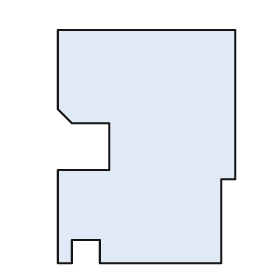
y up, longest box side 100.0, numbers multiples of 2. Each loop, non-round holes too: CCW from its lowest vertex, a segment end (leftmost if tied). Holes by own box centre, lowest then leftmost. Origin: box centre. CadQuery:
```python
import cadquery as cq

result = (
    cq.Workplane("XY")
    .moveTo(-38.0, -50.0)
    .lineTo(-32.0, -50.0)
    .lineTo(-32.0, -40.0)
    .lineTo(-20.0, -40.0)
    .lineTo(-20.0, -50.0)
    .lineTo(32.0, -50.0)
    .lineTo(32.0, -14.0)
    .lineTo(38.0, -14.0)
    .lineTo(38.0, 50.0)
    .lineTo(-38.0, 50.0)
    .lineTo(-38.0, 16.0)
    .lineTo(-32.0, 10.0)
    .lineTo(-16.0, 10.0)
    .lineTo(-16.0, -10.0)
    .lineTo(-38.0, -10.0)
    .close()
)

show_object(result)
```